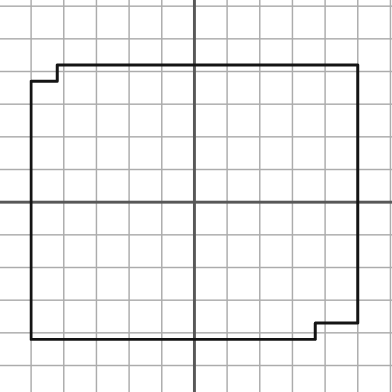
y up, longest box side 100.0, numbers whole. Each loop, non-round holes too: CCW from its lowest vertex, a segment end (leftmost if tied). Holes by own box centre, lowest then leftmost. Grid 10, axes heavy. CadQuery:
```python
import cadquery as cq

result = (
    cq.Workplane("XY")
    .moveTo(-50.0, -42.0)
    .lineTo(37.0, -42.0)
    .lineTo(37.0, -37.0)
    .lineTo(50.0, -37.0)
    .lineTo(50.0, 42.0)
    .lineTo(-42.0, 42.0)
    .lineTo(-42.0, 37.0)
    .lineTo(-50.0, 37.0)
    .close()
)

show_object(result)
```